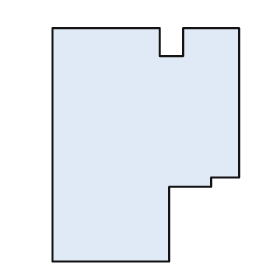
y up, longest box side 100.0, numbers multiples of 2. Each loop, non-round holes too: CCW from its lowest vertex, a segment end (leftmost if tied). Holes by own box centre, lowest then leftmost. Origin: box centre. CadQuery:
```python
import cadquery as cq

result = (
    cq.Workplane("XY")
    .moveTo(-40.0, -50.0)
    .lineTo(10.0, -50.0)
    .lineTo(10.0, -18.0)
    .lineTo(28.0, -18.0)
    .lineTo(28.0, -14.0)
    .lineTo(40.0, -14.0)
    .lineTo(40.0, 50.0)
    .lineTo(16.0, 50.0)
    .lineTo(16.0, 38.0)
    .lineTo(6.0, 38.0)
    .lineTo(6.0, 50.0)
    .lineTo(-40.0, 50.0)
    .close()
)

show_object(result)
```